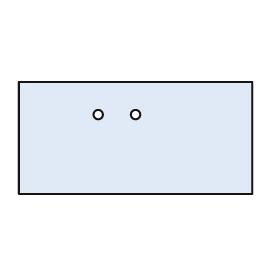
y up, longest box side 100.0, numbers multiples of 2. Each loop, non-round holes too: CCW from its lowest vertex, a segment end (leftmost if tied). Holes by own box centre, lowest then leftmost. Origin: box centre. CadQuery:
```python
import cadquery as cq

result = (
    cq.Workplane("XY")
    .moveTo(-50.0, -24.0)
    .lineTo(50.0, -24.0)
    .lineTo(50.0, 24.0)
    .lineTo(-50.0, 24.0)
    .close()
    .moveTo(-16.0, 10.0)
    .circle(2.0)
    .moveTo(0.0, 10.0)
    .circle(2.0)
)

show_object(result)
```